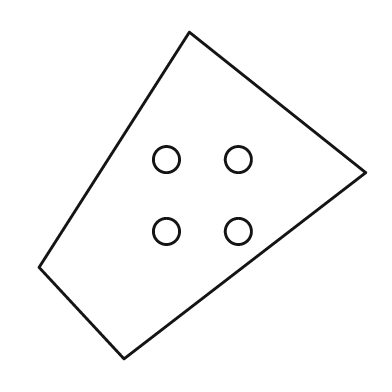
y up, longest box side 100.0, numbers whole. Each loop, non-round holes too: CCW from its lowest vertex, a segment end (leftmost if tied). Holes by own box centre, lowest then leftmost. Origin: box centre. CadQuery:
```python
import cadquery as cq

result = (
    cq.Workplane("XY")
    .moveTo(-24.0, -50.0)
    .lineTo(50.0, 7.0)
    .lineTo(-4.0, 50.0)
    .lineTo(-50.0, -22.0)
    .close()
    .moveTo(-11.0, -11.0)
    .circle(4.0)
    .moveTo(11.0, -11.0)
    .circle(4.0)
    .moveTo(-11.0, 11.0)
    .circle(4.0)
    .moveTo(11.0, 11.0)
    .circle(4.0)
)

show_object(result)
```